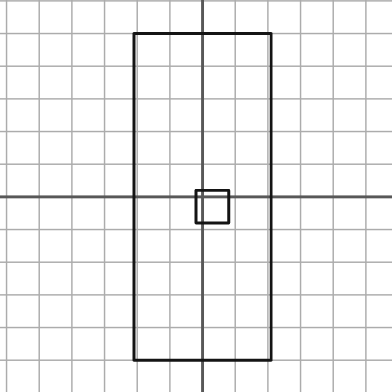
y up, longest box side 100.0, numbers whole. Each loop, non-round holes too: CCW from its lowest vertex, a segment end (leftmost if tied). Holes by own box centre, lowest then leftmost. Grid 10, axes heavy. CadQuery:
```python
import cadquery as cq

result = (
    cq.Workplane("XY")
    .moveTo(-21.0, -50.0)
    .lineTo(21.0, -50.0)
    .lineTo(21.0, 50.0)
    .lineTo(-21.0, 50.0)
    .close()
    .moveTo(-2.0, -8.0)
    .lineTo(8.0, -8.0)
    .lineTo(8.0, 2.0)
    .lineTo(-2.0, 2.0)
    .close()
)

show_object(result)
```